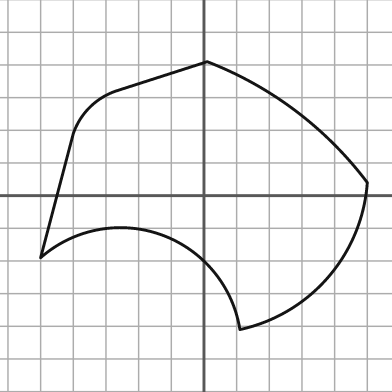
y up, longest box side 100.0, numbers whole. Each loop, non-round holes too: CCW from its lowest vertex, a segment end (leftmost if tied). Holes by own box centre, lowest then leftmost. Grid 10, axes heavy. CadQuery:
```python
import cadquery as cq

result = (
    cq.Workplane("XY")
    .moveTo(11.0, -41.0)
    .threePointArc((38.0, -25.0), (50.0, 4.0))
    .threePointArc((28.0, 26.0), (1.0, 41.0))
    .lineTo(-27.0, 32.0)
    .threePointArc((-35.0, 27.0), (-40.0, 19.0))
    .lineTo(-50.0, -19.0)
    .threePointArc((-13.0, -12.0), (11.0, -41.0))
    .close()
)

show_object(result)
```